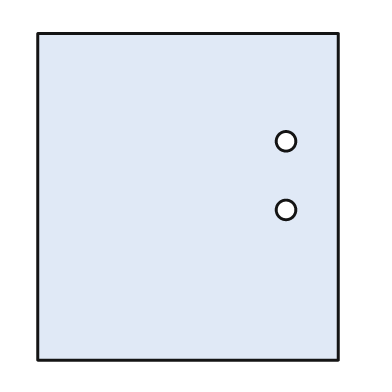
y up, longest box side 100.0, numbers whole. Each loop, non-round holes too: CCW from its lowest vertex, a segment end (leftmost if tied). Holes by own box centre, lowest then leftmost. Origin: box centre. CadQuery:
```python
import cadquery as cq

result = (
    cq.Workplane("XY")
    .moveTo(-46.0, -50.0)
    .lineTo(46.0, -50.0)
    .lineTo(46.0, 50.0)
    .lineTo(-46.0, 50.0)
    .close()
    .moveTo(30.0, -4.0)
    .circle(3.0)
    .moveTo(30.0, 17.0)
    .circle(3.0)
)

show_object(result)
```